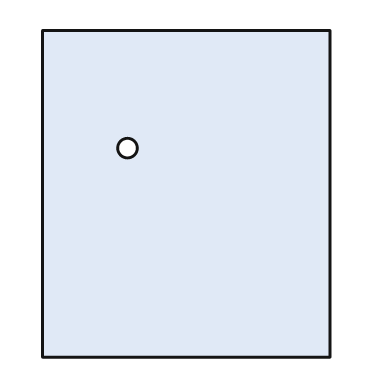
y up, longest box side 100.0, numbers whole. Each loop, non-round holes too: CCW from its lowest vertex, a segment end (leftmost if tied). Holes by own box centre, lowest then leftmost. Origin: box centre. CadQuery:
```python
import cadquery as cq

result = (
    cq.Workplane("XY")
    .moveTo(-44.0, -50.0)
    .lineTo(44.0, -50.0)
    .lineTo(44.0, 50.0)
    .lineTo(-44.0, 50.0)
    .close()
    .moveTo(-18.0, 14.0)
    .circle(3.0)
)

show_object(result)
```